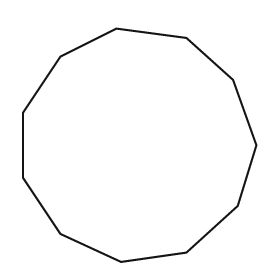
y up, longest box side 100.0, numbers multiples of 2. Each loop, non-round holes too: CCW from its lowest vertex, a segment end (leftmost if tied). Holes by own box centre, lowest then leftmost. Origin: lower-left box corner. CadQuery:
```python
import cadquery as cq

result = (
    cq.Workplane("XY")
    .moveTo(42.0, 0.0)
    .lineTo(70.0, 4.0)
    .lineTo(92.0, 24.0)
    .lineTo(100.0, 50.0)
    .lineTo(90.0, 78.0)
    .lineTo(70.0, 96.0)
    .lineTo(40.0, 100.0)
    .lineTo(16.0, 88.0)
    .lineTo(0.0, 64.0)
    .lineTo(0.0, 36.0)
    .lineTo(16.0, 12.0)
    .close()
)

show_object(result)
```